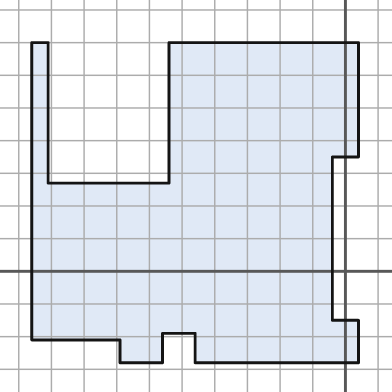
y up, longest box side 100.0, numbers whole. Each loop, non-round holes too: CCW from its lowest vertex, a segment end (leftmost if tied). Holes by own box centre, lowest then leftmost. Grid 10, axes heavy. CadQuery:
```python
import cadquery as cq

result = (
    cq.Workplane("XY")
    .moveTo(-69.0, -28.0)
    .lineTo(-56.0, -28.0)
    .lineTo(-56.0, -19.0)
    .lineTo(-46.0, -19.0)
    .lineTo(-46.0, -28.0)
    .lineTo(4.0, -28.0)
    .lineTo(4.0, -15.0)
    .lineTo(-4.0, -15.0)
    .lineTo(-4.0, 35.0)
    .lineTo(4.0, 35.0)
    .lineTo(4.0, 70.0)
    .lineTo(-54.0, 70.0)
    .lineTo(-54.0, 27.0)
    .lineTo(-91.0, 27.0)
    .lineTo(-91.0, 70.0)
    .lineTo(-96.0, 70.0)
    .lineTo(-96.0, -21.0)
    .lineTo(-69.0, -21.0)
    .close()
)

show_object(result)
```